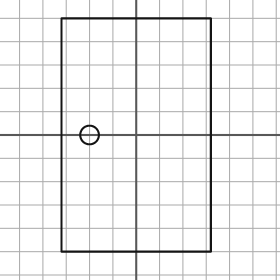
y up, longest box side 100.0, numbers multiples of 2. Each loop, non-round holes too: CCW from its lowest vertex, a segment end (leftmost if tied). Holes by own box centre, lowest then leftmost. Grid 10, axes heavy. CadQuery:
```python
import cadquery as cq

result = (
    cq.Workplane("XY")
    .moveTo(-32.0, -50.0)
    .lineTo(32.0, -50.0)
    .lineTo(32.0, 50.0)
    .lineTo(-32.0, 50.0)
    .close()
    .moveTo(-20.0, 0.0)
    .circle(4.0)
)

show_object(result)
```